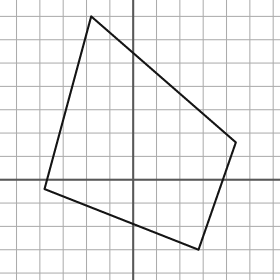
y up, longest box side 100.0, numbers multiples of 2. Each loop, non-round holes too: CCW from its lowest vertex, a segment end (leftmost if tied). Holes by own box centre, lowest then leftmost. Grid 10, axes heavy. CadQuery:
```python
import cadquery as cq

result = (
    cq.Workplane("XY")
    .moveTo(28.0, -30.0)
    .lineTo(44.0, 16.0)
    .lineTo(-18.0, 70.0)
    .lineTo(-38.0, -4.0)
    .close()
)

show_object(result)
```